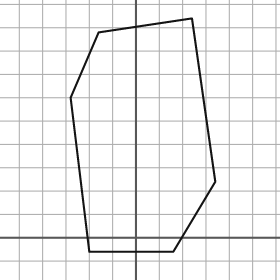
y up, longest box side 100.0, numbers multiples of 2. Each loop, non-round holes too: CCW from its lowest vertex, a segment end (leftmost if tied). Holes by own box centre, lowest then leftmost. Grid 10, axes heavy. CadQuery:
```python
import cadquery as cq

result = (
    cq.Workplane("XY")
    .moveTo(-20.0, -6.0)
    .lineTo(16.0, -6.0)
    .lineTo(34.0, 24.0)
    .lineTo(24.0, 94.0)
    .lineTo(-16.0, 88.0)
    .lineTo(-28.0, 60.0)
    .close()
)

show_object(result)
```